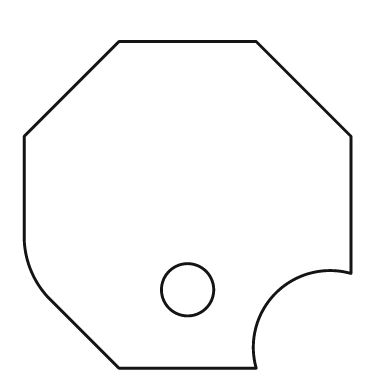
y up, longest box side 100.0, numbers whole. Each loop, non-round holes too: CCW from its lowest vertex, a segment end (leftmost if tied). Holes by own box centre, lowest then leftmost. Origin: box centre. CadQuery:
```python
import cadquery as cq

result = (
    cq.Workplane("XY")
    .moveTo(-21.0, -50.0)
    .lineTo(21.0, -50.0)
    .threePointArc((27.0, -27.0), (50.0, -21.0))
    .lineTo(50.0, 21.0)
    .lineTo(21.0, 50.0)
    .lineTo(-21.0, 50.0)
    .lineTo(-50.0, 21.0)
    .lineTo(-50.0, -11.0)
    .threePointArc((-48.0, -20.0), (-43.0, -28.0))
    .close()
    .moveTo(0.0, -26.0)
    .circle(8.0)
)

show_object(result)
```